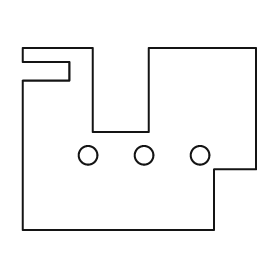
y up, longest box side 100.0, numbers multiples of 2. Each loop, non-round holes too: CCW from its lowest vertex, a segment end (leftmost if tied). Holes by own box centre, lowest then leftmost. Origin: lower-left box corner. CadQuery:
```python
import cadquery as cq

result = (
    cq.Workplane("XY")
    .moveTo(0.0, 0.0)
    .lineTo(82.0, 0.0)
    .lineTo(82.0, 26.0)
    .lineTo(100.0, 26.0)
    .lineTo(100.0, 78.0)
    .lineTo(54.0, 78.0)
    .lineTo(54.0, 42.0)
    .lineTo(30.0, 42.0)
    .lineTo(30.0, 78.0)
    .lineTo(0.0, 78.0)
    .lineTo(0.0, 72.0)
    .lineTo(20.0, 72.0)
    .lineTo(20.0, 64.0)
    .lineTo(0.0, 64.0)
    .close()
    .moveTo(28.0, 32.0)
    .circle(4.0)
    .moveTo(52.0, 32.0)
    .circle(4.0)
    .moveTo(76.0, 32.0)
    .circle(4.0)
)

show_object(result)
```